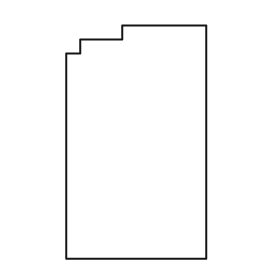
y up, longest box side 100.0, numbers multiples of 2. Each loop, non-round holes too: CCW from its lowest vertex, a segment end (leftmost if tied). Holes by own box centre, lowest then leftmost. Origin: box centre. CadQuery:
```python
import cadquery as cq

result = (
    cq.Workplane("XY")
    .moveTo(-30.0, -50.0)
    .lineTo(30.0, -50.0)
    .lineTo(30.0, 50.0)
    .lineTo(-6.0, 50.0)
    .lineTo(-6.0, 44.0)
    .lineTo(-24.0, 44.0)
    .lineTo(-24.0, 38.0)
    .lineTo(-30.0, 38.0)
    .close()
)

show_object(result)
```